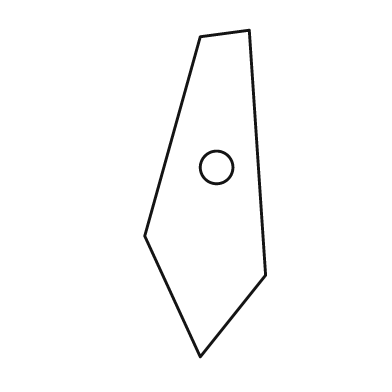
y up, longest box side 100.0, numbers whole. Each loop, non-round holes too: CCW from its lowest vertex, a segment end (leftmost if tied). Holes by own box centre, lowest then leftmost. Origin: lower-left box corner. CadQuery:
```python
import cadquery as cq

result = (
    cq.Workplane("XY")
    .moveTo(17.0, 0.0)
    .lineTo(37.0, 25.0)
    .lineTo(32.0, 100.0)
    .lineTo(17.0, 98.0)
    .lineTo(0.0, 37.0)
    .close()
    .moveTo(22.0, 58.0)
    .circle(5.0)
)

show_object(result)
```